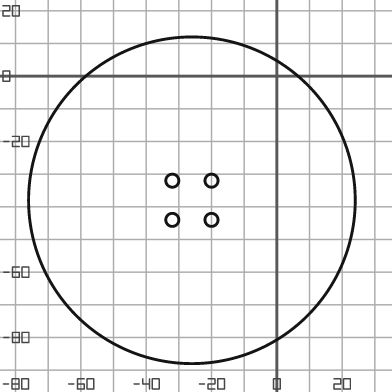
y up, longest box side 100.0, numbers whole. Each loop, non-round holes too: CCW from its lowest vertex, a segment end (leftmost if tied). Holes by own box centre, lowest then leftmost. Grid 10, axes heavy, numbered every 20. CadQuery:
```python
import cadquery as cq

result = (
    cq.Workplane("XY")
    .moveTo(-26.0, -38.0)
    .circle(50.0)
    .moveTo(-32.0, -44.0)
    .circle(2.0)
    .moveTo(-20.0, -44.0)
    .circle(2.0)
    .moveTo(-32.0, -32.0)
    .circle(2.0)
    .moveTo(-20.0, -32.0)
    .circle(2.0)
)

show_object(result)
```